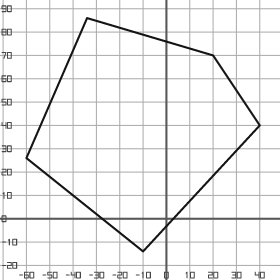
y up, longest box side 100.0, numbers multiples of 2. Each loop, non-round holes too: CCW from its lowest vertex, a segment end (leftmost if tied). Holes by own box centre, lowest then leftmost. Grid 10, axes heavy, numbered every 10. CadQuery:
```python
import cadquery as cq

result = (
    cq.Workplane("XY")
    .moveTo(-10.0, -14.0)
    .lineTo(40.0, 40.0)
    .lineTo(20.0, 70.0)
    .lineTo(-34.0, 86.0)
    .lineTo(-60.0, 26.0)
    .close()
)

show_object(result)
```